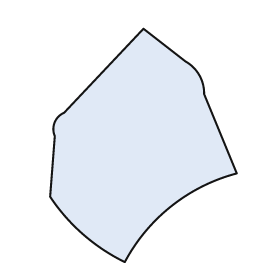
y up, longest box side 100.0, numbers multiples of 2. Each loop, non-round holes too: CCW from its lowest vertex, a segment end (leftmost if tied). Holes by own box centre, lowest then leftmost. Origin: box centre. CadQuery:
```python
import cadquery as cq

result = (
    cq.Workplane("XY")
    .moveTo(-8.0, -50.0)
    .threePointArc((12.0, -26.0), (40.0, -12.0))
    .lineTo(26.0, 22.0)
    .threePointArc((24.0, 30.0), (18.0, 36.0))
    .lineTo(0.0, 50.0)
    .lineTo(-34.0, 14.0)
    .threePointArc((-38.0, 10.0), (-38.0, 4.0))
    .lineTo(-40.0, -22.0)
    .threePointArc((-26.0, -38.0), (-8.0, -50.0))
    .close()
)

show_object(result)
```